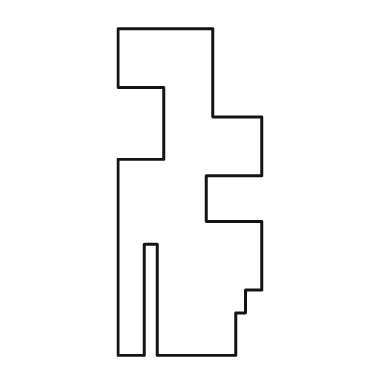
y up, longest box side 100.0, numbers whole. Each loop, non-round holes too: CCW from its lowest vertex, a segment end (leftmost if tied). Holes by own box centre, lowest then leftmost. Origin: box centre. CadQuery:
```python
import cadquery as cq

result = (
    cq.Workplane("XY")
    .moveTo(-22.0, -50.0)
    .lineTo(-14.0, -50.0)
    .lineTo(-14.0, -16.0)
    .lineTo(-10.0, -16.0)
    .lineTo(-10.0, -50.0)
    .lineTo(14.0, -50.0)
    .lineTo(14.0, -37.0)
    .lineTo(17.0, -37.0)
    .lineTo(17.0, -30.0)
    .lineTo(22.0, -30.0)
    .lineTo(22.0, -9.0)
    .lineTo(5.0, -9.0)
    .lineTo(5.0, 5.0)
    .lineTo(22.0, 5.0)
    .lineTo(22.0, 23.0)
    .lineTo(7.0, 23.0)
    .lineTo(7.0, 50.0)
    .lineTo(-22.0, 50.0)
    .lineTo(-22.0, 32.0)
    .lineTo(-8.0, 32.0)
    .lineTo(-8.0, 10.0)
    .lineTo(-22.0, 10.0)
    .close()
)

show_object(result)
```